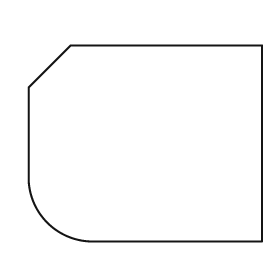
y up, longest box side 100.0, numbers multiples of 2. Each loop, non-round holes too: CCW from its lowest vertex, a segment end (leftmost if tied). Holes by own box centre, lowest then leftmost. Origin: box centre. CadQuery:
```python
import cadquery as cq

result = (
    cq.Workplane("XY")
    .moveTo(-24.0, -42.0)
    .lineTo(50.0, -42.0)
    .lineTo(50.0, 42.0)
    .lineTo(-32.0, 42.0)
    .lineTo(-50.0, 24.0)
    .lineTo(-50.0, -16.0)
    .threePointArc((-42.0, -34.0), (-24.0, -42.0))
    .close()
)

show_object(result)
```